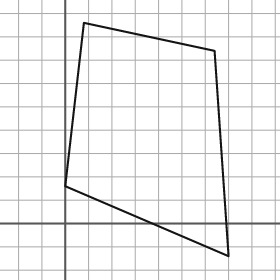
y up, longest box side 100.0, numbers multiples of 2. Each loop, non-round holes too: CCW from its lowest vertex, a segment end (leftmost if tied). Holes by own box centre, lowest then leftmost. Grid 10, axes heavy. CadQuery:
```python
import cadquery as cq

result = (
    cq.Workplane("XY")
    .moveTo(70.0, -14.0)
    .lineTo(64.0, 74.0)
    .lineTo(8.0, 86.0)
    .lineTo(0.0, 16.0)
    .close()
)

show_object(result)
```